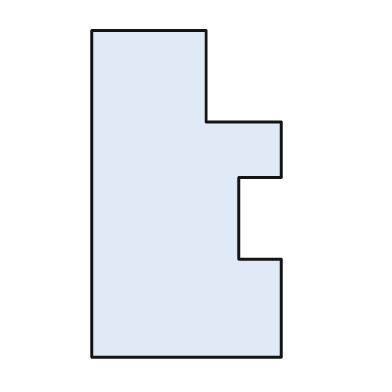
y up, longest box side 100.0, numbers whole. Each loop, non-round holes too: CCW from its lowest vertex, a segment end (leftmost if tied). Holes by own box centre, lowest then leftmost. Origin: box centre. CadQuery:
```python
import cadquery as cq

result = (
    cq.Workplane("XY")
    .moveTo(-29.0, -50.0)
    .lineTo(29.0, -50.0)
    .lineTo(29.0, -20.0)
    .lineTo(16.0, -20.0)
    .lineTo(16.0, 5.0)
    .lineTo(29.0, 5.0)
    .lineTo(29.0, 22.0)
    .lineTo(6.0, 22.0)
    .lineTo(6.0, 50.0)
    .lineTo(-29.0, 50.0)
    .close()
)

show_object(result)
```